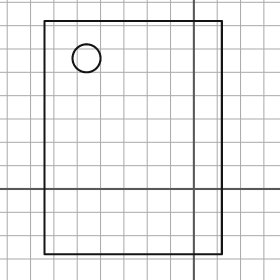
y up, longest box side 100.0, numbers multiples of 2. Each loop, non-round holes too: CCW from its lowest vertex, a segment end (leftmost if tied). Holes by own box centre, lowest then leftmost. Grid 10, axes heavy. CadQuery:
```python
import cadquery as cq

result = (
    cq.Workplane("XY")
    .moveTo(-64.0, -28.0)
    .lineTo(12.0, -28.0)
    .lineTo(12.0, 72.0)
    .lineTo(-64.0, 72.0)
    .close()
    .moveTo(-46.0, 56.0)
    .circle(6.0)
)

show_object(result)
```